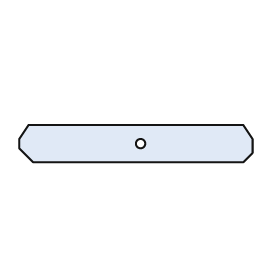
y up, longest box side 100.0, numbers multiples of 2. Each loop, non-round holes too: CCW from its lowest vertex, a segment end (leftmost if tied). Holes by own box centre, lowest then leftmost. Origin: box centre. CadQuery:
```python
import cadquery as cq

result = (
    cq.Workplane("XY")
    .moveTo(-44.0, -8.0)
    .lineTo(46.0, -8.0)
    .lineTo(50.0, -4.0)
    .lineTo(50.0, 2.0)
    .lineTo(46.0, 8.0)
    .lineTo(-46.0, 8.0)
    .lineTo(-50.0, 2.0)
    .lineTo(-50.0, -2.0)
    .close()
    .moveTo(2.0, 0.0)
    .circle(2.0)
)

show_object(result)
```